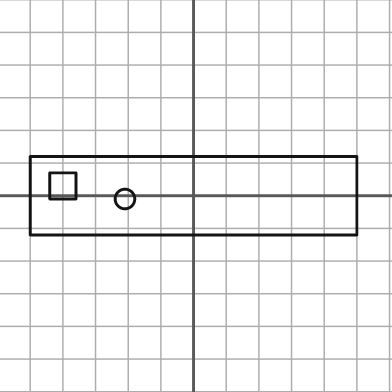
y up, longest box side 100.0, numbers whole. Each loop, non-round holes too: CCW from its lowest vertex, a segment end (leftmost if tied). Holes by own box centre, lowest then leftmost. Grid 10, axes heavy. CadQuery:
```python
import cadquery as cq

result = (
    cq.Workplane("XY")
    .moveTo(-50.0, -12.0)
    .lineTo(50.0, -12.0)
    .lineTo(50.0, 12.0)
    .lineTo(-50.0, 12.0)
    .close()
    .moveTo(-21.0, -1.0)
    .circle(3.0)
    .moveTo(-44.0, -1.0)
    .lineTo(-36.0, -1.0)
    .lineTo(-36.0, 7.0)
    .lineTo(-44.0, 7.0)
    .close()
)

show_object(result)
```